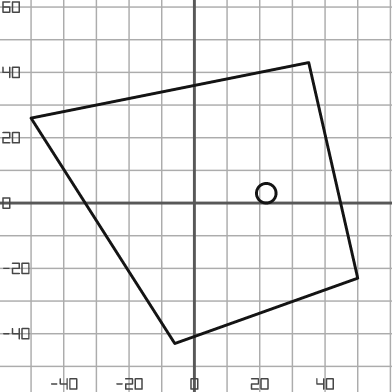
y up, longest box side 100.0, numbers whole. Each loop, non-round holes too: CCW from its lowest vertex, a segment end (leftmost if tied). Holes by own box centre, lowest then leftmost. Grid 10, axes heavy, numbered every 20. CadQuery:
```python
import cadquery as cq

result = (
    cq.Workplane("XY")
    .moveTo(-6.0, -43.0)
    .lineTo(50.0, -23.0)
    .lineTo(35.0, 43.0)
    .lineTo(-50.0, 26.0)
    .close()
    .moveTo(22.0, 3.0)
    .circle(3.0)
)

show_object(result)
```